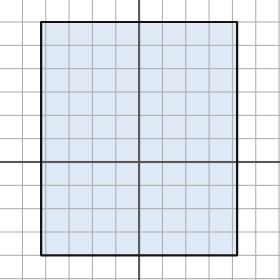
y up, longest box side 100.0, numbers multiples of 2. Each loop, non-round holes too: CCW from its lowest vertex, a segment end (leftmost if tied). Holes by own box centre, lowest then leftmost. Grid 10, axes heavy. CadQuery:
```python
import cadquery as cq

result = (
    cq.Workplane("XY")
    .moveTo(-42.0, -40.0)
    .lineTo(42.0, -40.0)
    .lineTo(42.0, 60.0)
    .lineTo(-42.0, 60.0)
    .close()
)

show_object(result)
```